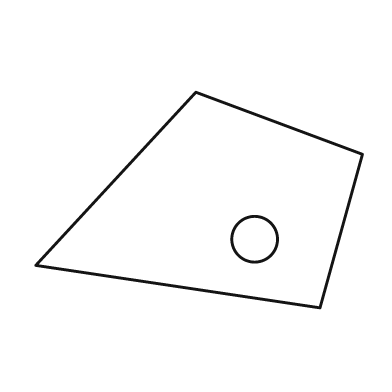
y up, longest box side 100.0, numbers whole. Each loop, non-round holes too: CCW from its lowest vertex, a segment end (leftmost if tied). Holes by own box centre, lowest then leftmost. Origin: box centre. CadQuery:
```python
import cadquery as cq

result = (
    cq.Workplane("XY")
    .moveTo(37.0, -33.0)
    .lineTo(50.0, 14.0)
    .lineTo(-1.0, 33.0)
    .lineTo(-50.0, -20.0)
    .close()
    .moveTo(17.0, -12.0)
    .circle(7.0)
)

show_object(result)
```